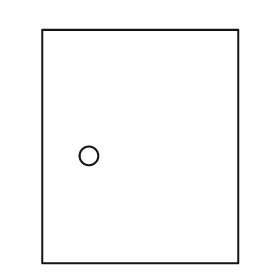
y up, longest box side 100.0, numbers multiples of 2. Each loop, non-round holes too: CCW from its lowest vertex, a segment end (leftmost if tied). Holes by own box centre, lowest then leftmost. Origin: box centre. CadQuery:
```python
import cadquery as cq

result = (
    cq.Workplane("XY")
    .moveTo(-42.0, -50.0)
    .lineTo(42.0, -50.0)
    .lineTo(42.0, 50.0)
    .lineTo(-42.0, 50.0)
    .close()
    .moveTo(-22.0, -4.0)
    .circle(4.0)
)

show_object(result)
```